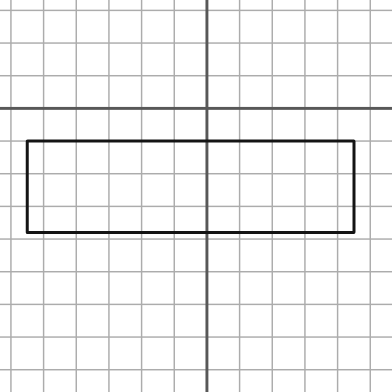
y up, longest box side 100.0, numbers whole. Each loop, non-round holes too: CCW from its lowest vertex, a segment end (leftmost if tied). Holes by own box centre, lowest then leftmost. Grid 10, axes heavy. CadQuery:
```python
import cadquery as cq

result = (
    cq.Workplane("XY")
    .moveTo(-55.0, -38.0)
    .lineTo(45.0, -38.0)
    .lineTo(45.0, -10.0)
    .lineTo(-55.0, -10.0)
    .close()
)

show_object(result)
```